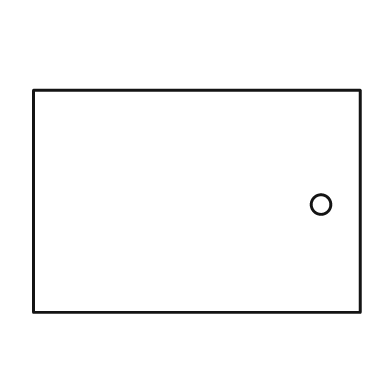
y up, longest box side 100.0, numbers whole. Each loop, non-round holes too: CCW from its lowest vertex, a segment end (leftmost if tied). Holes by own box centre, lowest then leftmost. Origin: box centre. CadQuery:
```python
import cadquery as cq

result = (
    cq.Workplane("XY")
    .moveTo(-50.0, -34.0)
    .lineTo(50.0, -34.0)
    .lineTo(50.0, 34.0)
    .lineTo(-50.0, 34.0)
    .close()
    .moveTo(38.0, -1.0)
    .circle(3.0)
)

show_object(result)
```